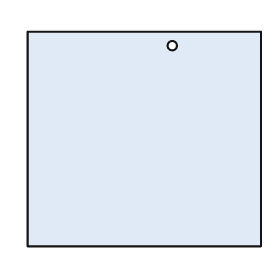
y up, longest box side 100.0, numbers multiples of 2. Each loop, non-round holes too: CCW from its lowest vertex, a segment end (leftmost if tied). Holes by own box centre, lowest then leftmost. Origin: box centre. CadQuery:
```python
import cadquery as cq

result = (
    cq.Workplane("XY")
    .moveTo(-50.0, -46.0)
    .lineTo(50.0, -46.0)
    .lineTo(50.0, 46.0)
    .lineTo(-50.0, 46.0)
    .close()
    .moveTo(12.0, 40.0)
    .circle(2.0)
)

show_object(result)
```